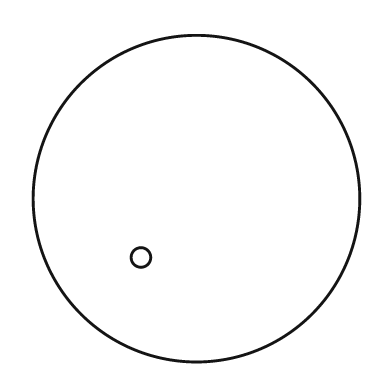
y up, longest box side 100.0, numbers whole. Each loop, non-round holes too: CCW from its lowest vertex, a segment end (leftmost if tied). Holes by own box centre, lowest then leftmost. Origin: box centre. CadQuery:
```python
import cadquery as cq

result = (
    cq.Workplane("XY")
    .moveTo(0.0, 0.0)
    .circle(50.0)
    .moveTo(-17.0, -18.0)
    .circle(3.0)
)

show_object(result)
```